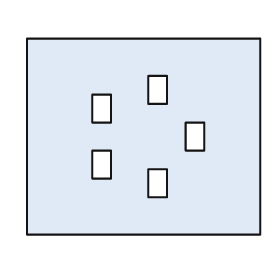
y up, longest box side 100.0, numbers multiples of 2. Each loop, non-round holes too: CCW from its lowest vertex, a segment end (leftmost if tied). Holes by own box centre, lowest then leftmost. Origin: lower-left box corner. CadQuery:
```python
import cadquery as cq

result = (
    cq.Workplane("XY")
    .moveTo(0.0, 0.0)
    .lineTo(100.0, 0.0)
    .lineTo(100.0, 84.0)
    .lineTo(0.0, 84.0)
    .close()
    .moveTo(52.0, 16.0)
    .lineTo(60.0, 16.0)
    .lineTo(60.0, 28.0)
    .lineTo(52.0, 28.0)
    .close()
    .moveTo(28.0, 24.0)
    .lineTo(36.0, 24.0)
    .lineTo(36.0, 36.0)
    .lineTo(28.0, 36.0)
    .close()
    .moveTo(68.0, 36.0)
    .lineTo(76.0, 36.0)
    .lineTo(76.0, 48.0)
    .lineTo(68.0, 48.0)
    .close()
    .moveTo(28.0, 48.0)
    .lineTo(36.0, 48.0)
    .lineTo(36.0, 60.0)
    .lineTo(28.0, 60.0)
    .close()
    .moveTo(52.0, 56.0)
    .lineTo(60.0, 56.0)
    .lineTo(60.0, 68.0)
    .lineTo(52.0, 68.0)
    .close()
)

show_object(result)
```